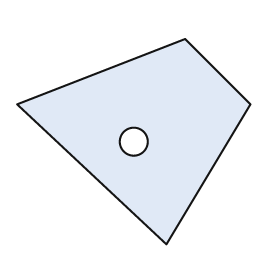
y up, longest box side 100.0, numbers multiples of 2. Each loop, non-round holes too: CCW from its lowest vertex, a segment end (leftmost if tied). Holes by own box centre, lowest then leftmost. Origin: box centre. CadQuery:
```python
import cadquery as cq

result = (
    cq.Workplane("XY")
    .moveTo(14.0, -44.0)
    .lineTo(50.0, 16.0)
    .lineTo(22.0, 44.0)
    .lineTo(-50.0, 16.0)
    .close()
    .moveTo(0.0, 0.0)
    .circle(6.0)
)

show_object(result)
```